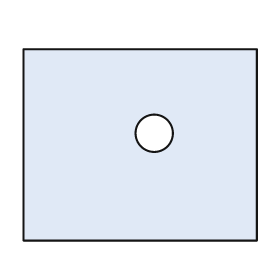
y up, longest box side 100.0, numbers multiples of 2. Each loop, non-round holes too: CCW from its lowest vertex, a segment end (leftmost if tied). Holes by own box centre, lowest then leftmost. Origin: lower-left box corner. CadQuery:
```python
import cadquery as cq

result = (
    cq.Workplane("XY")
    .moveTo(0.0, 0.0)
    .lineTo(100.0, 0.0)
    .lineTo(100.0, 82.0)
    .lineTo(0.0, 82.0)
    .close()
    .moveTo(56.0, 46.0)
    .circle(8.0)
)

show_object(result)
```